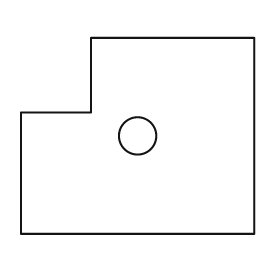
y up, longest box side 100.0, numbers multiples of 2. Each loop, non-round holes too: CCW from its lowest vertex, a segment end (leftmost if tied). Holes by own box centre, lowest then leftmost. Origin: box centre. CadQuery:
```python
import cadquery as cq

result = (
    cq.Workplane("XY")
    .moveTo(-50.0, -42.0)
    .lineTo(50.0, -42.0)
    .lineTo(50.0, 42.0)
    .lineTo(-20.0, 42.0)
    .lineTo(-20.0, 10.0)
    .lineTo(-50.0, 10.0)
    .close()
    .moveTo(0.0, 0.0)
    .circle(8.0)
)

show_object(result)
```